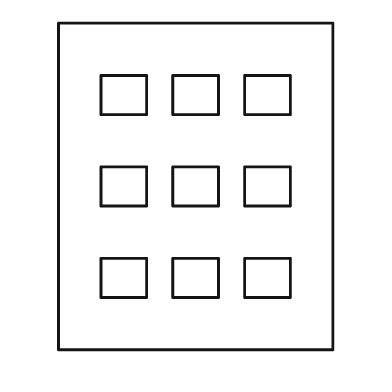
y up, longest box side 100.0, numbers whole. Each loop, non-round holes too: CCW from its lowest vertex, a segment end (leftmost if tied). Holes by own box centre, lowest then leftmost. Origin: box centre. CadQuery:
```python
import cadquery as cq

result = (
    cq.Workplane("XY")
    .moveTo(-42.0, -50.0)
    .lineTo(42.0, -50.0)
    .lineTo(42.0, 50.0)
    .lineTo(-42.0, 50.0)
    .close()
    .moveTo(-29.0, -34.0)
    .lineTo(-15.0, -34.0)
    .lineTo(-15.0, -22.0)
    .lineTo(-29.0, -22.0)
    .close()
    .moveTo(-7.0, -34.0)
    .lineTo(7.0, -34.0)
    .lineTo(7.0, -22.0)
    .lineTo(-7.0, -22.0)
    .close()
    .moveTo(15.0, -34.0)
    .lineTo(29.0, -34.0)
    .lineTo(29.0, -22.0)
    .lineTo(15.0, -22.0)
    .close()
    .moveTo(-29.0, -6.0)
    .lineTo(-15.0, -6.0)
    .lineTo(-15.0, 6.0)
    .lineTo(-29.0, 6.0)
    .close()
    .moveTo(-7.0, -6.0)
    .lineTo(7.0, -6.0)
    .lineTo(7.0, 6.0)
    .lineTo(-7.0, 6.0)
    .close()
    .moveTo(15.0, -6.0)
    .lineTo(29.0, -6.0)
    .lineTo(29.0, 6.0)
    .lineTo(15.0, 6.0)
    .close()
    .moveTo(-29.0, 22.0)
    .lineTo(-15.0, 22.0)
    .lineTo(-15.0, 34.0)
    .lineTo(-29.0, 34.0)
    .close()
    .moveTo(-7.0, 22.0)
    .lineTo(7.0, 22.0)
    .lineTo(7.0, 34.0)
    .lineTo(-7.0, 34.0)
    .close()
    .moveTo(15.0, 22.0)
    .lineTo(29.0, 22.0)
    .lineTo(29.0, 34.0)
    .lineTo(15.0, 34.0)
    .close()
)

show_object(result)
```